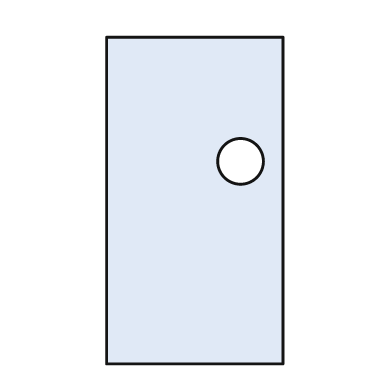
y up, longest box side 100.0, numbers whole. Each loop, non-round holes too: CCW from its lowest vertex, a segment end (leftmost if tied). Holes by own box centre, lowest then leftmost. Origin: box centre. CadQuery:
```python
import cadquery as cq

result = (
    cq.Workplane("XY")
    .moveTo(-27.0, -50.0)
    .lineTo(27.0, -50.0)
    .lineTo(27.0, 50.0)
    .lineTo(-27.0, 50.0)
    .close()
    .moveTo(14.0, 12.0)
    .circle(7.0)
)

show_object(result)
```